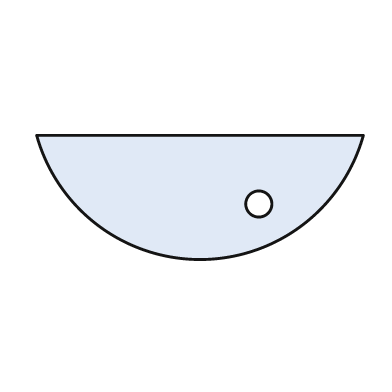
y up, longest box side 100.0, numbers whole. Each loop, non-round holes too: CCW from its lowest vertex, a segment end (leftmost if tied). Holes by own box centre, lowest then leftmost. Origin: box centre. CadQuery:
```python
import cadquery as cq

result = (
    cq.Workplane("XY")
    .moveTo(-50.0, 19.0)
    .threePointArc((0.0, -19.0), (50.0, 19.0))
    .close()
    .moveTo(18.0, -2.0)
    .circle(4.0)
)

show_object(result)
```